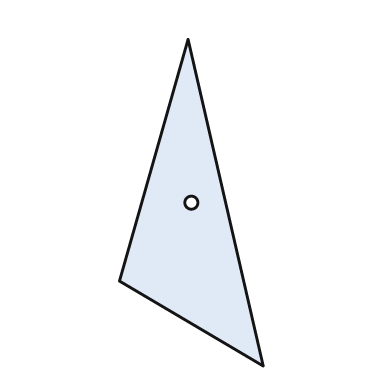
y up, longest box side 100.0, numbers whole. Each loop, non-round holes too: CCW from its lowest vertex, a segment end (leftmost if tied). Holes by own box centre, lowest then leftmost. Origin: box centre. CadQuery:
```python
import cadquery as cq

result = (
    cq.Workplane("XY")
    .moveTo(22.0, -50.0)
    .lineTo(-1.0, 50.0)
    .lineTo(-22.0, -24.0)
    .close()
    .moveTo(0.0, 0.0)
    .circle(2.0)
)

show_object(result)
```